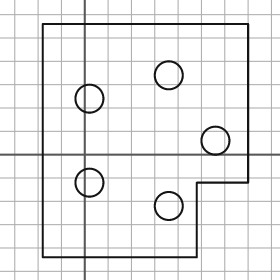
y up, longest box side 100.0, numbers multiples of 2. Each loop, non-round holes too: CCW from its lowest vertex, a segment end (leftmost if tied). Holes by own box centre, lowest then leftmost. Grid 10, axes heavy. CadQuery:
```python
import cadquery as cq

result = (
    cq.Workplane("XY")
    .moveTo(-18.0, -44.0)
    .lineTo(48.0, -44.0)
    .lineTo(48.0, -12.0)
    .lineTo(70.0, -12.0)
    .lineTo(70.0, 56.0)
    .lineTo(-18.0, 56.0)
    .close()
    .moveTo(36.0, -22.0)
    .circle(6.0)
    .moveTo(2.0, -12.0)
    .circle(6.0)
    .moveTo(56.0, 6.0)
    .circle(6.0)
    .moveTo(2.0, 24.0)
    .circle(6.0)
    .moveTo(36.0, 34.0)
    .circle(6.0)
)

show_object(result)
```